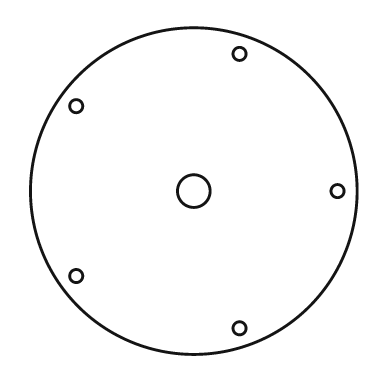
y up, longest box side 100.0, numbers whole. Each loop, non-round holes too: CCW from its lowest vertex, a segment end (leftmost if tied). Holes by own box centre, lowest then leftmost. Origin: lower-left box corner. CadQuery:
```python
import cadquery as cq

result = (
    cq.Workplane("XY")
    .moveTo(50.0, 50.0)
    .circle(50.0)
    .moveTo(64.0, 8.0)
    .circle(2.0)
    .moveTo(14.0, 24.0)
    .circle(2.0)
    .moveTo(50.0, 50.0)
    .circle(5.0)
    .moveTo(94.0, 50.0)
    .circle(2.0)
    .moveTo(14.0, 76.0)
    .circle(2.0)
    .moveTo(64.0, 92.0)
    .circle(2.0)
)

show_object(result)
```